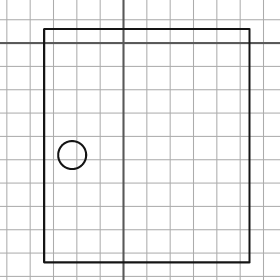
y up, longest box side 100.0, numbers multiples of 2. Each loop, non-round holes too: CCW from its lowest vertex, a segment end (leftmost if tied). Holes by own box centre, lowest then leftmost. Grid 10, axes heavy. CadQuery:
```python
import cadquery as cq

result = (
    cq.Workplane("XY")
    .moveTo(-34.0, -94.0)
    .lineTo(54.0, -94.0)
    .lineTo(54.0, 6.0)
    .lineTo(-34.0, 6.0)
    .close()
    .moveTo(-22.0, -48.0)
    .circle(6.0)
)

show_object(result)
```